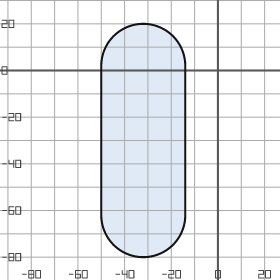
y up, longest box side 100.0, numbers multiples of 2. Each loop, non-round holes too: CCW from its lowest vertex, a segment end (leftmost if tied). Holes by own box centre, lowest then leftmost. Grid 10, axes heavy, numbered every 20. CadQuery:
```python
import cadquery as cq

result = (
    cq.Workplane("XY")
    .moveTo(-50.0, -62.0)
    .threePointArc((-32.0, -80.0), (-14.0, -62.0))
    .lineTo(-14.0, 2.0)
    .threePointArc((-32.0, 20.0), (-50.0, 2.0))
    .close()
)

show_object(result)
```